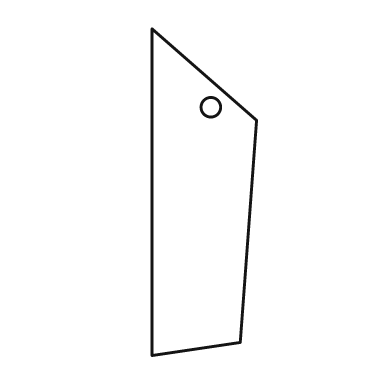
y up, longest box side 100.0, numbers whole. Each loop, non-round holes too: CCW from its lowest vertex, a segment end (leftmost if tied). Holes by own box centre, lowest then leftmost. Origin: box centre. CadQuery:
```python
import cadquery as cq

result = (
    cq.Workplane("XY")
    .moveTo(-16.0, -50.0)
    .lineTo(11.0, -46.0)
    .lineTo(16.0, 22.0)
    .lineTo(-16.0, 50.0)
    .close()
    .moveTo(2.0, 26.0)
    .circle(3.0)
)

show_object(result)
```